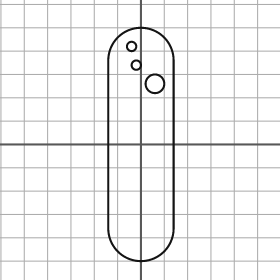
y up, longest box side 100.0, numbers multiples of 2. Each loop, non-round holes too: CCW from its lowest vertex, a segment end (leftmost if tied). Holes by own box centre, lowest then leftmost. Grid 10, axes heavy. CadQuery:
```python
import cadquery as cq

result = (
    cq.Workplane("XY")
    .moveTo(-14.0, -36.0)
    .threePointArc((0.0, -50.0), (14.0, -36.0))
    .lineTo(14.0, 36.0)
    .threePointArc((0.0, 50.0), (-14.0, 36.0))
    .close()
    .moveTo(6.0, 26.0)
    .circle(4.0)
    .moveTo(-2.0, 34.0)
    .circle(2.0)
    .moveTo(-4.0, 42.0)
    .circle(2.0)
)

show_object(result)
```